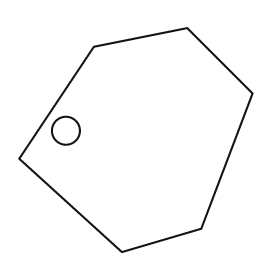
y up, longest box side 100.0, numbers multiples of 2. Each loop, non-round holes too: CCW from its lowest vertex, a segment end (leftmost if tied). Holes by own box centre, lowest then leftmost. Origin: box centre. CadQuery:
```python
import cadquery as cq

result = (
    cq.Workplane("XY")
    .moveTo(-6.0, -48.0)
    .lineTo(28.0, -38.0)
    .lineTo(50.0, 20.0)
    .lineTo(22.0, 48.0)
    .lineTo(-18.0, 40.0)
    .lineTo(-50.0, -8.0)
    .close()
    .moveTo(-30.0, 4.0)
    .circle(6.0)
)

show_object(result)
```